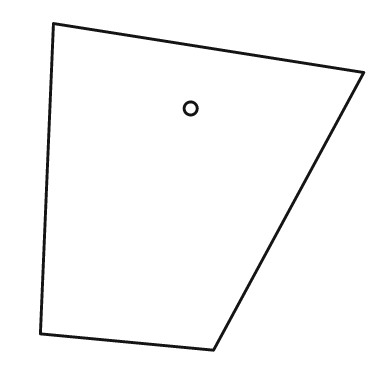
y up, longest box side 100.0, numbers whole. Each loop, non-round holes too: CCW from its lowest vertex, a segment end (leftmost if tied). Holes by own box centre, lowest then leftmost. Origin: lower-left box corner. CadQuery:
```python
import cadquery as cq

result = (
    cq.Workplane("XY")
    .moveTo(53.0, 0.0)
    .lineTo(99.0, 85.0)
    .lineTo(4.0, 100.0)
    .lineTo(0.0, 5.0)
    .close()
    .moveTo(46.0, 74.0)
    .circle(2.0)
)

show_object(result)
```